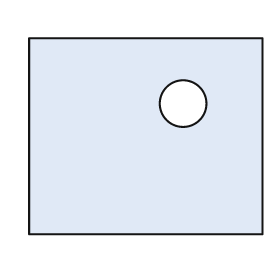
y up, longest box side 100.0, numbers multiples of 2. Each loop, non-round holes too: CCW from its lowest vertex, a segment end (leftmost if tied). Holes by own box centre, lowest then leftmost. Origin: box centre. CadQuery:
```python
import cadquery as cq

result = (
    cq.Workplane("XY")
    .moveTo(-50.0, -42.0)
    .lineTo(50.0, -42.0)
    .lineTo(50.0, 42.0)
    .lineTo(-50.0, 42.0)
    .close()
    .moveTo(16.0, 14.0)
    .circle(10.0)
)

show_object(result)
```